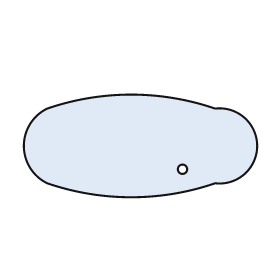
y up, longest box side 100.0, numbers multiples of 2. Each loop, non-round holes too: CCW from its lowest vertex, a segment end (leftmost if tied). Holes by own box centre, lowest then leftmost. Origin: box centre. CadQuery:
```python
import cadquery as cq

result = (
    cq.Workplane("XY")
    .moveTo(-40.0, -16.0)
    .threePointArc((-4.0, -22.0), (32.0, -16.0))
    .threePointArc((50.0, 0.0), (32.0, 16.0))
    .threePointArc((-4.0, 22.0), (-40.0, 16.0))
    .threePointArc((-50.0, 0.0), (-40.0, -16.0))
    .close()
    .moveTo(18.0, -10.0)
    .circle(2.0)
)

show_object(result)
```